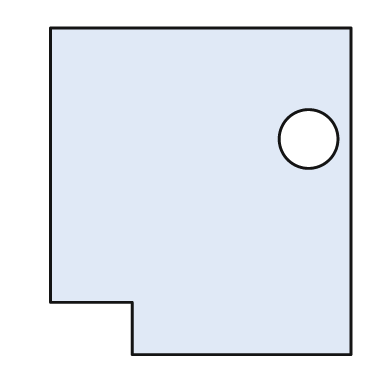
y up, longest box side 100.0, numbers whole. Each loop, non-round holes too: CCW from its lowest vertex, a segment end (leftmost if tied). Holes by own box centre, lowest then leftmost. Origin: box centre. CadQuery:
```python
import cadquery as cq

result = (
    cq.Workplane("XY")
    .moveTo(-21.0, -50.0)
    .lineTo(46.0, -50.0)
    .lineTo(46.0, 50.0)
    .lineTo(-46.0, 50.0)
    .lineTo(-46.0, -34.0)
    .lineTo(-21.0, -34.0)
    .close()
    .moveTo(33.0, 16.0)
    .circle(9.0)
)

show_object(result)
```